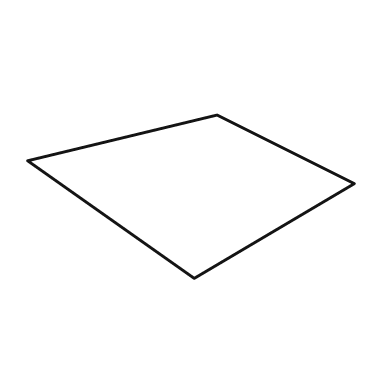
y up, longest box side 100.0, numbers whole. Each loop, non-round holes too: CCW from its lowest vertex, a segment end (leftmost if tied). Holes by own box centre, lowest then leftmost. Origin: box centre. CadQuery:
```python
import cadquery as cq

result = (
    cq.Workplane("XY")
    .moveTo(1.0, -25.0)
    .lineTo(50.0, 4.0)
    .lineTo(8.0, 25.0)
    .lineTo(-50.0, 11.0)
    .close()
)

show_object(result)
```